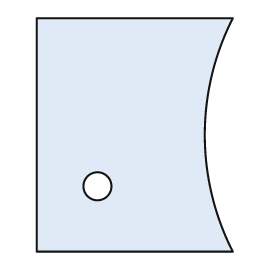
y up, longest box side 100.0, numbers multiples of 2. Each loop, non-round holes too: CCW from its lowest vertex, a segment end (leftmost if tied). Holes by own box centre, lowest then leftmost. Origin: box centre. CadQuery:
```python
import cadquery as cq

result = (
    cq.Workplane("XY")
    .moveTo(-42.0, -50.0)
    .lineTo(42.0, -50.0)
    .threePointArc((30.0, 0.0), (42.0, 50.0))
    .lineTo(-42.0, 50.0)
    .close()
    .moveTo(-16.0, -22.0)
    .circle(6.0)
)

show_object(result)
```